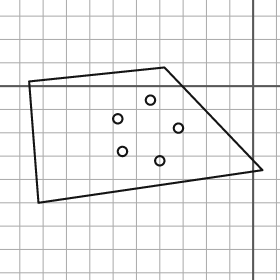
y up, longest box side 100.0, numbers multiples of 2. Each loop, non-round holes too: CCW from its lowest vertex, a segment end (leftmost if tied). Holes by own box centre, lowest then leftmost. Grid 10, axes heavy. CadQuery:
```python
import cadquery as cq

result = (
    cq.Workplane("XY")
    .moveTo(-92.0, -50.0)
    .lineTo(4.0, -36.0)
    .lineTo(-38.0, 8.0)
    .lineTo(-96.0, 2.0)
    .close()
    .moveTo(-40.0, -32.0)
    .circle(2.0)
    .moveTo(-56.0, -28.0)
    .circle(2.0)
    .moveTo(-32.0, -18.0)
    .circle(2.0)
    .moveTo(-58.0, -14.0)
    .circle(2.0)
    .moveTo(-44.0, -6.0)
    .circle(2.0)
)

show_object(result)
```